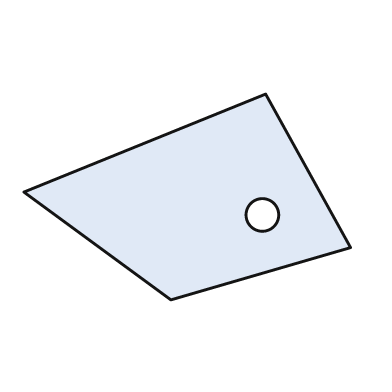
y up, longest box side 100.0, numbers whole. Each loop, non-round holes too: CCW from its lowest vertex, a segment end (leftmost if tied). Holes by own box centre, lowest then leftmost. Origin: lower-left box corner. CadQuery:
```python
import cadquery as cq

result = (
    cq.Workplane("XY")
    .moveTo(45.0, 0.0)
    .lineTo(100.0, 16.0)
    .lineTo(74.0, 63.0)
    .lineTo(0.0, 33.0)
    .close()
    .moveTo(73.0, 26.0)
    .circle(5.0)
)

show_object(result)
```